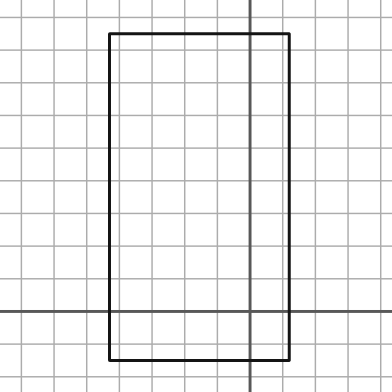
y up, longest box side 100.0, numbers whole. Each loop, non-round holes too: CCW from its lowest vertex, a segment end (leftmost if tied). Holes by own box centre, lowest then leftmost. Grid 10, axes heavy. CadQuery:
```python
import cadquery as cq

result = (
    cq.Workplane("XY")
    .moveTo(-43.0, -15.0)
    .lineTo(12.0, -15.0)
    .lineTo(12.0, 85.0)
    .lineTo(-43.0, 85.0)
    .close()
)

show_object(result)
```